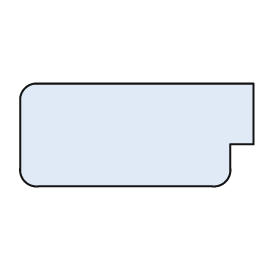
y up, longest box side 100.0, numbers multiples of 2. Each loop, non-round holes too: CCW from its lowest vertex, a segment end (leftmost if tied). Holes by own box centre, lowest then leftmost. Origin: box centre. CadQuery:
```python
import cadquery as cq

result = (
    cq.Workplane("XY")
    .moveTo(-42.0, -22.0)
    .lineTo(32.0, -22.0)
    .threePointArc((38.0, -20.0), (40.0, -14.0))
    .lineTo(40.0, -4.0)
    .lineTo(50.0, -4.0)
    .lineTo(50.0, 22.0)
    .lineTo(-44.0, 22.0)
    .threePointArc((-48.0, 20.0), (-50.0, 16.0))
    .lineTo(-50.0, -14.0)
    .threePointArc((-48.0, -20.0), (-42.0, -22.0))
    .close()
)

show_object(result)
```